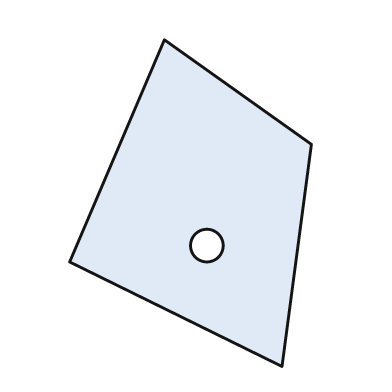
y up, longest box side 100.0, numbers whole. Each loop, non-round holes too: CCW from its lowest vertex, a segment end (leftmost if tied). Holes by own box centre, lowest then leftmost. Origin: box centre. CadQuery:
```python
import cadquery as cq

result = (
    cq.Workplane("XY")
    .moveTo(28.0, -50.0)
    .lineTo(37.0, 18.0)
    .lineTo(-8.0, 50.0)
    .lineTo(-37.0, -18.0)
    .close()
    .moveTo(5.0, -13.0)
    .circle(5.0)
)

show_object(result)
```